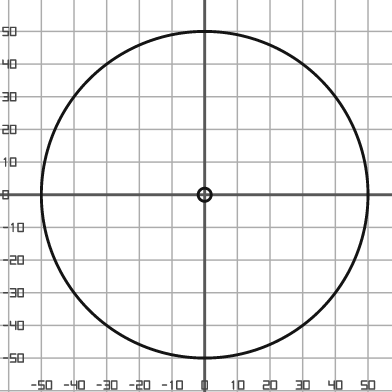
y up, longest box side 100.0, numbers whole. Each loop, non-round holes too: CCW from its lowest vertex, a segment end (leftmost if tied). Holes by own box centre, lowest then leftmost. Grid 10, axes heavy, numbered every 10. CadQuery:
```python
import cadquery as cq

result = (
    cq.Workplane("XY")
    .moveTo(0.0, 0.0)
    .circle(50.0)
    .moveTo(0.0, 0.0)
    .circle(2.0)
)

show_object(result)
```